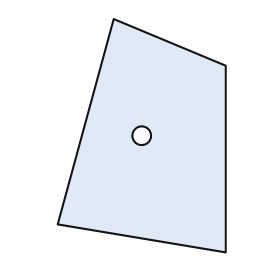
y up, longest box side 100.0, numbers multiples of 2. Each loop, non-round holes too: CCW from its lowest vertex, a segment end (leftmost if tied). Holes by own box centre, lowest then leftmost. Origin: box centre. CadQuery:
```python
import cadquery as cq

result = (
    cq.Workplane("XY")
    .moveTo(36.0, -50.0)
    .lineTo(36.0, 30.0)
    .lineTo(-12.0, 50.0)
    .lineTo(-36.0, -38.0)
    .close()
    .moveTo(0.0, 0.0)
    .circle(4.0)
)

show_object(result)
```